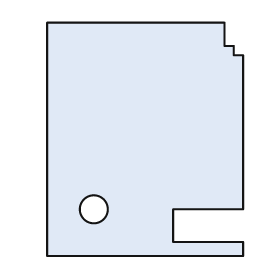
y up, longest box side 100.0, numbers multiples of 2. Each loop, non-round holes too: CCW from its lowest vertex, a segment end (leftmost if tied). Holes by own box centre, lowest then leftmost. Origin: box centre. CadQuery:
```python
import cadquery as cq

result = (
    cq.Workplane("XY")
    .moveTo(-42.0, -50.0)
    .lineTo(42.0, -50.0)
    .lineTo(42.0, -44.0)
    .lineTo(12.0, -44.0)
    .lineTo(12.0, -30.0)
    .lineTo(42.0, -30.0)
    .lineTo(42.0, 36.0)
    .lineTo(38.0, 36.0)
    .lineTo(38.0, 40.0)
    .lineTo(34.0, 40.0)
    .lineTo(34.0, 50.0)
    .lineTo(-42.0, 50.0)
    .close()
    .moveTo(-22.0, -30.0)
    .circle(6.0)
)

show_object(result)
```